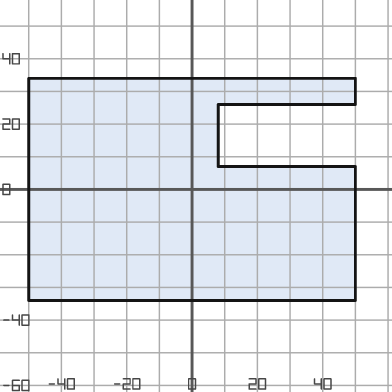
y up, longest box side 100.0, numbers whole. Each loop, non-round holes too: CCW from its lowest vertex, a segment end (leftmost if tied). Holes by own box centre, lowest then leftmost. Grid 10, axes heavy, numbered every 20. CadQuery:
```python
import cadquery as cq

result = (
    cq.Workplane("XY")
    .moveTo(-50.0, -34.0)
    .lineTo(50.0, -34.0)
    .lineTo(50.0, 7.0)
    .lineTo(8.0, 7.0)
    .lineTo(8.0, 26.0)
    .lineTo(50.0, 26.0)
    .lineTo(50.0, 34.0)
    .lineTo(-50.0, 34.0)
    .close()
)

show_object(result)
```